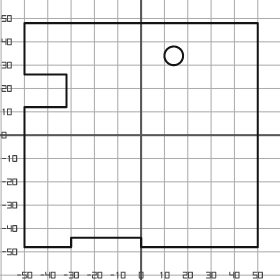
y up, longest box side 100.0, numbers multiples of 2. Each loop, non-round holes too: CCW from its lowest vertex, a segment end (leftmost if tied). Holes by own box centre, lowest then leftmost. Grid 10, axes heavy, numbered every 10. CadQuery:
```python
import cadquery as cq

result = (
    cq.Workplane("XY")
    .moveTo(-50.0, -48.0)
    .lineTo(-30.0, -48.0)
    .lineTo(-30.0, -44.0)
    .lineTo(0.0, -44.0)
    .lineTo(0.0, -48.0)
    .lineTo(50.0, -48.0)
    .lineTo(50.0, 48.0)
    .lineTo(-50.0, 48.0)
    .lineTo(-50.0, 26.0)
    .lineTo(-32.0, 26.0)
    .lineTo(-32.0, 12.0)
    .lineTo(-50.0, 12.0)
    .close()
    .moveTo(14.0, 34.0)
    .circle(4.0)
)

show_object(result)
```